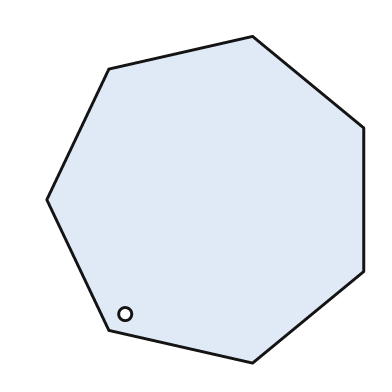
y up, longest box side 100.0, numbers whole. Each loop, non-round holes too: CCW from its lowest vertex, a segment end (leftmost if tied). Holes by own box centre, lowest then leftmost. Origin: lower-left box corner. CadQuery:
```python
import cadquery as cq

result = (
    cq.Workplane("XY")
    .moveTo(63.0, 0.0)
    .lineTo(97.0, 28.0)
    .lineTo(97.0, 72.0)
    .lineTo(63.0, 100.0)
    .lineTo(19.0, 90.0)
    .lineTo(0.0, 50.0)
    .lineTo(19.0, 10.0)
    .close()
    .moveTo(24.0, 15.0)
    .circle(2.0)
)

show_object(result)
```